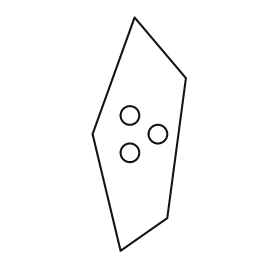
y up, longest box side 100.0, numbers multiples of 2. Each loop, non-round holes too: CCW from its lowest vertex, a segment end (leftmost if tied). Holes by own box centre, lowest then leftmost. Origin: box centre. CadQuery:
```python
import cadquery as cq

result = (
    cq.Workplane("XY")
    .moveTo(-8.0, -50.0)
    .lineTo(12.0, -36.0)
    .lineTo(20.0, 24.0)
    .lineTo(-2.0, 50.0)
    .lineTo(-20.0, 0.0)
    .close()
    .moveTo(-4.0, -8.0)
    .circle(4.0)
    .moveTo(8.0, 0.0)
    .circle(4.0)
    .moveTo(-4.0, 8.0)
    .circle(4.0)
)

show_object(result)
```